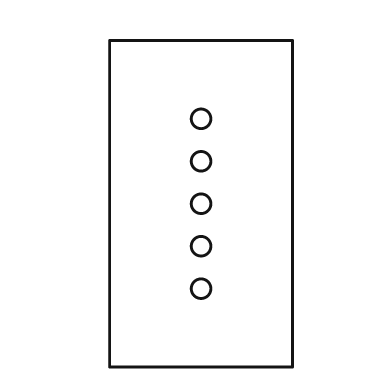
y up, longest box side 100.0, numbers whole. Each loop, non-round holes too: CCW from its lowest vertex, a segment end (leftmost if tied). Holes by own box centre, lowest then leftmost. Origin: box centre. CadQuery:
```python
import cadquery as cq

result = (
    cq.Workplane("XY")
    .moveTo(-28.0, -50.0)
    .lineTo(28.0, -50.0)
    .lineTo(28.0, 50.0)
    .lineTo(-28.0, 50.0)
    .close()
    .moveTo(0.0, -26.0)
    .circle(3.0)
    .moveTo(0.0, -13.0)
    .circle(3.0)
    .moveTo(0.0, 0.0)
    .circle(3.0)
    .moveTo(0.0, 13.0)
    .circle(3.0)
    .moveTo(0.0, 26.0)
    .circle(3.0)
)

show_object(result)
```